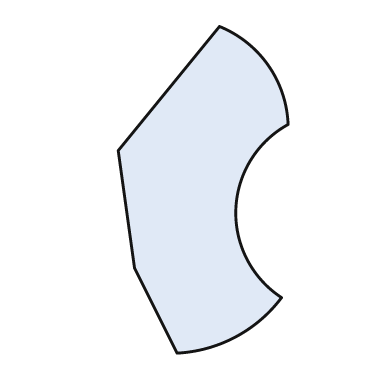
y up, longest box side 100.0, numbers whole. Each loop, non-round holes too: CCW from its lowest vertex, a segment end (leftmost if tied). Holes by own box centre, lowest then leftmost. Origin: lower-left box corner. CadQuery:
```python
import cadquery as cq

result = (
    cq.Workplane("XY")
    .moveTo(18.0, 0.0)
    .threePointArc((36.0, 5.0), (50.0, 17.0))
    .threePointArc((36.0, 44.0), (52.0, 70.0))
    .threePointArc((46.0, 88.0), (31.0, 100.0))
    .lineTo(0.0, 62.0)
    .lineTo(5.0, 26.0)
    .close()
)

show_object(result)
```